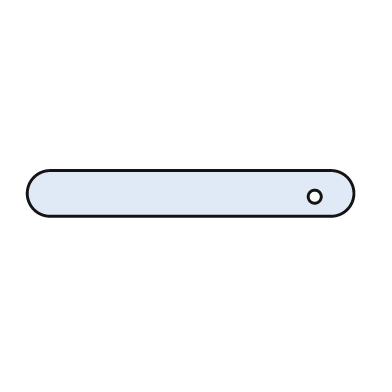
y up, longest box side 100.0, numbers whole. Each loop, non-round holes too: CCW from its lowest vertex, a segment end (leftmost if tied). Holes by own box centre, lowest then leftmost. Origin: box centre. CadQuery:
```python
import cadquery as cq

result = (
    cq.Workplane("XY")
    .moveTo(-43.0, -7.0)
    .lineTo(43.0, -7.0)
    .threePointArc((50.0, 0.0), (43.0, 7.0))
    .lineTo(-43.0, 7.0)
    .threePointArc((-50.0, 0.0), (-43.0, -7.0))
    .close()
    .moveTo(38.0, -1.0)
    .circle(2.0)
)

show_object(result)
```